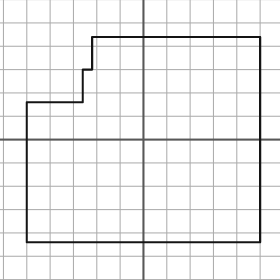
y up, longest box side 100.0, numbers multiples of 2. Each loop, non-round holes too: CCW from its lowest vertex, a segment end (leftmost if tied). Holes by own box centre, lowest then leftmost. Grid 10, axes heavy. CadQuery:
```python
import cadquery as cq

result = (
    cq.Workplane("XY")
    .moveTo(-50.0, -44.0)
    .lineTo(50.0, -44.0)
    .lineTo(50.0, 44.0)
    .lineTo(-22.0, 44.0)
    .lineTo(-22.0, 30.0)
    .lineTo(-26.0, 30.0)
    .lineTo(-26.0, 16.0)
    .lineTo(-50.0, 16.0)
    .close()
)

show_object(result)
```